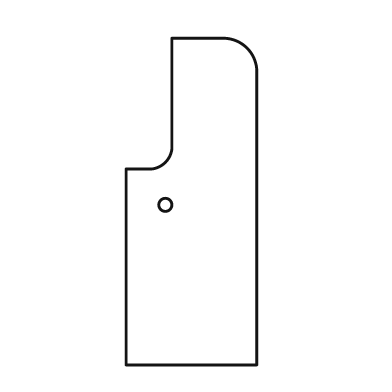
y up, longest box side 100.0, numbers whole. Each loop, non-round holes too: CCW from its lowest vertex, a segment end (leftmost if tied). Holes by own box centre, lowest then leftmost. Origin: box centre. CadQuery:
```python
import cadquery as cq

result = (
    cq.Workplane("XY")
    .moveTo(-20.0, -50.0)
    .lineTo(20.0, -50.0)
    .lineTo(20.0, 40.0)
    .threePointArc((17.0, 47.0), (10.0, 50.0))
    .lineTo(-6.0, 50.0)
    .lineTo(-6.0, 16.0)
    .threePointArc((-8.0, 12.0), (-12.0, 10.0))
    .lineTo(-20.0, 10.0)
    .close()
    .moveTo(-8.0, -1.0)
    .circle(2.0)
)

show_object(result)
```